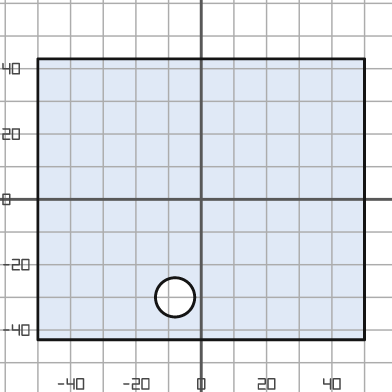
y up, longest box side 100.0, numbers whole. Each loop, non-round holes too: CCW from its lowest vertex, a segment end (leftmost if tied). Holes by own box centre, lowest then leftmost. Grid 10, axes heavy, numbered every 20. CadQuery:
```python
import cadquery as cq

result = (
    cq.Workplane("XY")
    .moveTo(-50.0, -43.0)
    .lineTo(50.0, -43.0)
    .lineTo(50.0, 43.0)
    .lineTo(-50.0, 43.0)
    .close()
    .moveTo(-8.0, -30.0)
    .circle(6.0)
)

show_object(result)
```